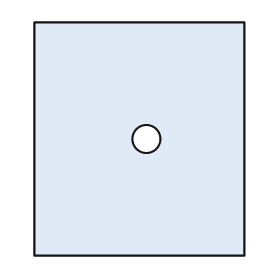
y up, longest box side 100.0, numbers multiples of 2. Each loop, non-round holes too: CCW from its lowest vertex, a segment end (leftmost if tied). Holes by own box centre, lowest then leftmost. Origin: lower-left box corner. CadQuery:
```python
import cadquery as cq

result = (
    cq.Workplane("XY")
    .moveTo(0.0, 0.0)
    .lineTo(90.0, 0.0)
    .lineTo(90.0, 100.0)
    .lineTo(0.0, 100.0)
    .close()
    .moveTo(48.0, 50.0)
    .circle(6.0)
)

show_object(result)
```